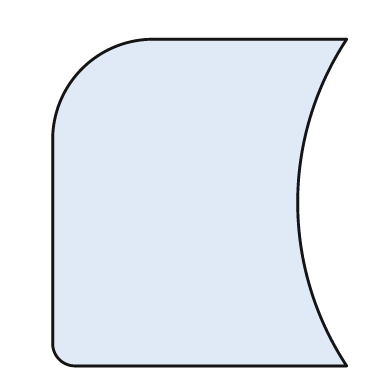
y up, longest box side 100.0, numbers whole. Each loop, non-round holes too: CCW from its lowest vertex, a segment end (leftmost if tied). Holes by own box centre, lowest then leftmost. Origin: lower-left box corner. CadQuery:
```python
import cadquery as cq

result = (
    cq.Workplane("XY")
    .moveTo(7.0, 0.0)
    .lineTo(90.0, 0.0)
    .threePointArc((75.0, 50.0), (90.0, 100.0))
    .lineTo(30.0, 100.0)
    .threePointArc((9.0, 91.0), (0.0, 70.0))
    .lineTo(0.0, 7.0)
    .threePointArc((2.0, 2.0), (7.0, 0.0))
    .close()
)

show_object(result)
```